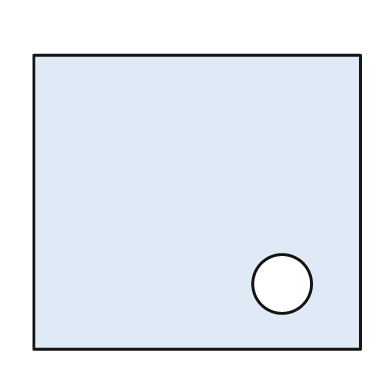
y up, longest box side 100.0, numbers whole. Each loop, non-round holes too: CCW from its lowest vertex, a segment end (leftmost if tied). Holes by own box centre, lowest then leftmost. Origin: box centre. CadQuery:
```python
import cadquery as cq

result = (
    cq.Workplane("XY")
    .moveTo(-50.0, -45.0)
    .lineTo(50.0, -45.0)
    .lineTo(50.0, 45.0)
    .lineTo(-50.0, 45.0)
    .close()
    .moveTo(26.0, -25.0)
    .circle(9.0)
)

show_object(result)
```